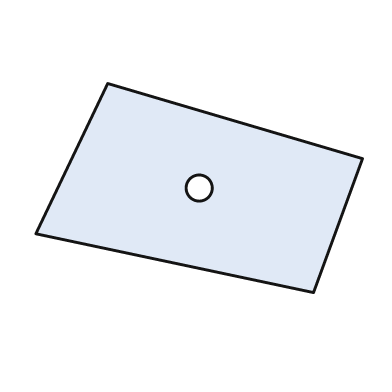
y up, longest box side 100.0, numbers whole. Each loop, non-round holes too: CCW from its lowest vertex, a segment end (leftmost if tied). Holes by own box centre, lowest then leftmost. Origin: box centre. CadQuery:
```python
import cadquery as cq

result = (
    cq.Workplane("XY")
    .moveTo(35.0, -32.0)
    .lineTo(50.0, 9.0)
    .lineTo(-28.0, 32.0)
    .lineTo(-50.0, -14.0)
    .close()
    .moveTo(0.0, 0.0)
    .circle(4.0)
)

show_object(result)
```